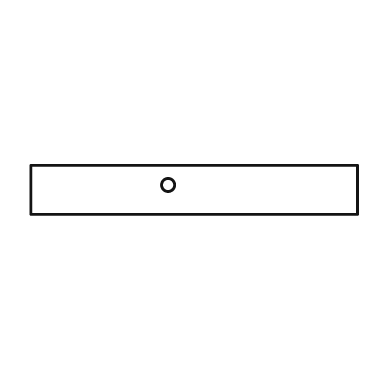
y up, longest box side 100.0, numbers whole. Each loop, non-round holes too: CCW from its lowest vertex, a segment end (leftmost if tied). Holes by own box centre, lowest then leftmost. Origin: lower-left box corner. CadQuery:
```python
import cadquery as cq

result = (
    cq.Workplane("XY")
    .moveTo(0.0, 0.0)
    .lineTo(100.0, 0.0)
    .lineTo(100.0, 15.0)
    .lineTo(0.0, 15.0)
    .close()
    .moveTo(42.0, 9.0)
    .circle(2.0)
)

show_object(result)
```